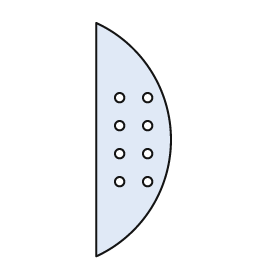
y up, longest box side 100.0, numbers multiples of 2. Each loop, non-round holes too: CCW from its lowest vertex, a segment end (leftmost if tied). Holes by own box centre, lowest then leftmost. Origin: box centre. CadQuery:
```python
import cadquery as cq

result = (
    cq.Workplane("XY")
    .moveTo(-16.0, -50.0)
    .threePointArc((16.0, 0.0), (-16.0, 50.0))
    .close()
    .moveTo(-6.0, -18.0)
    .circle(2.0)
    .moveTo(6.0, -18.0)
    .circle(2.0)
    .moveTo(-6.0, -6.0)
    .circle(2.0)
    .moveTo(6.0, -6.0)
    .circle(2.0)
    .moveTo(-6.0, 6.0)
    .circle(2.0)
    .moveTo(6.0, 6.0)
    .circle(2.0)
    .moveTo(-6.0, 18.0)
    .circle(2.0)
    .moveTo(6.0, 18.0)
    .circle(2.0)
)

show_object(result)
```